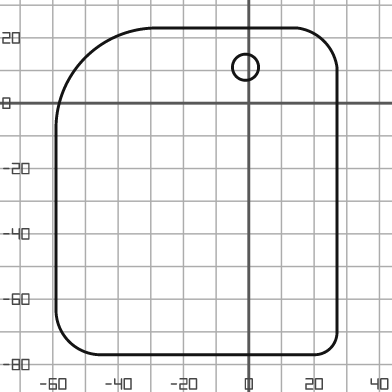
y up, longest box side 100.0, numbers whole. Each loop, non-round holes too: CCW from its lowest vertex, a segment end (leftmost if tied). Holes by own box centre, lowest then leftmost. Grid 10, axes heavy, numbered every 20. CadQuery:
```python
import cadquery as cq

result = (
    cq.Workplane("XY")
    .moveTo(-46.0, -77.0)
    .lineTo(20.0, -77.0)
    .threePointArc((25.0, -75.0), (27.0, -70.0))
    .lineTo(27.0, 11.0)
    .threePointArc((23.0, 19.0), (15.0, 23.0))
    .lineTo(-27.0, 23.0)
    .threePointArc((-50.0, 14.0), (-59.0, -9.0))
    .lineTo(-59.0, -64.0)
    .threePointArc((-55.0, -73.0), (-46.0, -77.0))
    .close()
    .moveTo(-1.0, 11.0)
    .circle(4.0)
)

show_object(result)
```